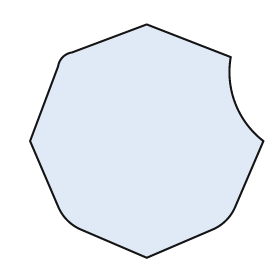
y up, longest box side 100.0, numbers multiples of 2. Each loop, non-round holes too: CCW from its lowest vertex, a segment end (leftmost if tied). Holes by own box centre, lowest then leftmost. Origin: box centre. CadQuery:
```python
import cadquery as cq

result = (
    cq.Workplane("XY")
    .moveTo(0.0, -50.0)
    .lineTo(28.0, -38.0)
    .threePointArc((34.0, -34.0), (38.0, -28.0))
    .lineTo(50.0, 0.0)
    .threePointArc((38.0, 16.0), (36.0, 36.0))
    .lineTo(0.0, 50.0)
    .lineTo(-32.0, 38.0)
    .threePointArc((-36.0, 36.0), (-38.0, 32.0))
    .lineTo(-50.0, 0.0)
    .lineTo(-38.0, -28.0)
    .threePointArc((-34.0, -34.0), (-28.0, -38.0))
    .close()
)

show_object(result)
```